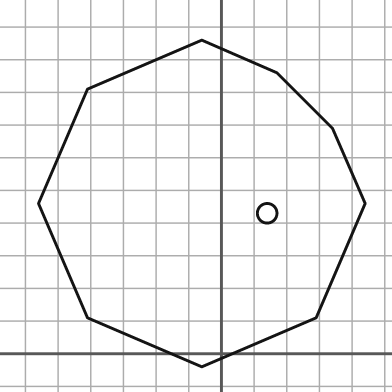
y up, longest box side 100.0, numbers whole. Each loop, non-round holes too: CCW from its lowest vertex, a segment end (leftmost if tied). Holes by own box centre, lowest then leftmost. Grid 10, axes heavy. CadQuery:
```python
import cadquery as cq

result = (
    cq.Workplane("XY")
    .moveTo(-6.0, -4.0)
    .lineTo(29.0, 11.0)
    .lineTo(44.0, 46.0)
    .lineTo(34.0, 69.0)
    .lineTo(17.0, 86.0)
    .lineTo(-6.0, 96.0)
    .lineTo(-41.0, 81.0)
    .lineTo(-56.0, 46.0)
    .lineTo(-41.0, 11.0)
    .close()
    .moveTo(14.0, 43.0)
    .circle(3.0)
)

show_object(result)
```